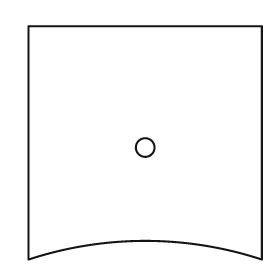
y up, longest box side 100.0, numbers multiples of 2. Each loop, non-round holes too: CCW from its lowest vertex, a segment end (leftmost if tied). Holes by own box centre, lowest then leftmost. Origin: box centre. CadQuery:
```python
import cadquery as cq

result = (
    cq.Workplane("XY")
    .moveTo(-50.0, -50.0)
    .threePointArc((0.0, -42.0), (50.0, -50.0))
    .lineTo(50.0, 50.0)
    .lineTo(-50.0, 50.0)
    .close()
    .moveTo(0.0, -2.0)
    .circle(4.0)
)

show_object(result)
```